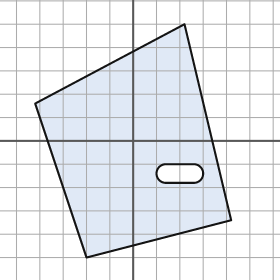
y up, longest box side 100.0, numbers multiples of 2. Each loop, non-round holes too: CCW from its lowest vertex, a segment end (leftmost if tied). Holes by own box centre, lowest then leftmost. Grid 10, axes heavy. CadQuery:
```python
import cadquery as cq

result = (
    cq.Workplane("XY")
    .moveTo(-20.0, -50.0)
    .lineTo(42.0, -34.0)
    .lineTo(22.0, 50.0)
    .lineTo(-42.0, 16.0)
    .close()
    .moveTo(14.0, -18.0)
    .lineTo(26.0, -18.0)
    .threePointArc((30.0, -14.0), (26.0, -10.0))
    .lineTo(14.0, -10.0)
    .threePointArc((10.0, -14.0), (14.0, -18.0))
    .close()
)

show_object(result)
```